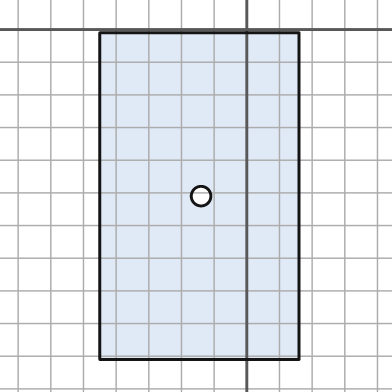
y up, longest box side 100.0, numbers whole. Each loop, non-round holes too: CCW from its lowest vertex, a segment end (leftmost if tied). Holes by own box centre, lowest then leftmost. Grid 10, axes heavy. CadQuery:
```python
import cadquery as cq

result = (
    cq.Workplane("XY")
    .moveTo(-45.0, -101.0)
    .lineTo(16.0, -101.0)
    .lineTo(16.0, -1.0)
    .lineTo(-45.0, -1.0)
    .close()
    .moveTo(-14.0, -51.0)
    .circle(3.0)
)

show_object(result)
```